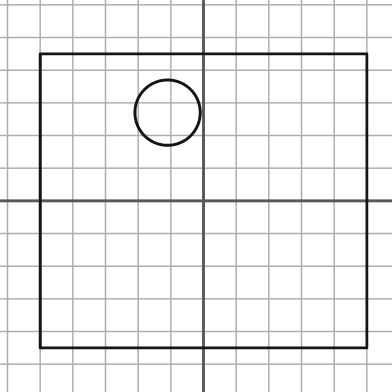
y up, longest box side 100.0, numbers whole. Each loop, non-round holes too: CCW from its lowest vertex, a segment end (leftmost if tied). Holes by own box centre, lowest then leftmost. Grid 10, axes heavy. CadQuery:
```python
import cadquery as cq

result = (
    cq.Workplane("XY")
    .moveTo(-50.0, -45.0)
    .lineTo(50.0, -45.0)
    .lineTo(50.0, 45.0)
    .lineTo(-50.0, 45.0)
    .close()
    .moveTo(-11.0, 27.0)
    .circle(10.0)
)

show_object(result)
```